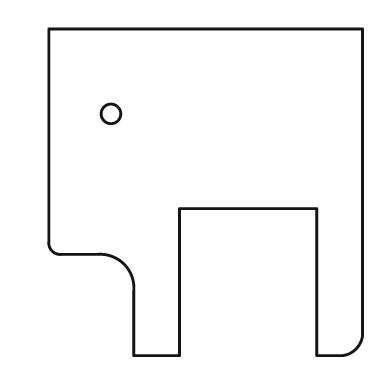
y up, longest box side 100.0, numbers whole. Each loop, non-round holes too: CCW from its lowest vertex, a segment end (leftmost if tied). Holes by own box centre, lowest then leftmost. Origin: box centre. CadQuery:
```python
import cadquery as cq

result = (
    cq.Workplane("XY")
    .moveTo(-22.0, -50.0)
    .lineTo(-8.0, -50.0)
    .lineTo(-8.0, -5.0)
    .lineTo(34.0, -5.0)
    .lineTo(34.0, -50.0)
    .lineTo(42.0, -50.0)
    .threePointArc((46.0, -48.0), (48.0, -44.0))
    .lineTo(48.0, 50.0)
    .lineTo(-48.0, 50.0)
    .lineTo(-48.0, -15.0)
    .threePointArc((-47.0, -18.0), (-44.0, -19.0))
    .lineTo(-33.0, -19.0)
    .threePointArc((-25.0, -22.0), (-22.0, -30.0))
    .close()
    .moveTo(-29.0, 24.0)
    .circle(3.0)
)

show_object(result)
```